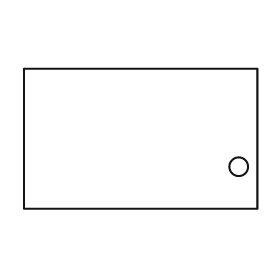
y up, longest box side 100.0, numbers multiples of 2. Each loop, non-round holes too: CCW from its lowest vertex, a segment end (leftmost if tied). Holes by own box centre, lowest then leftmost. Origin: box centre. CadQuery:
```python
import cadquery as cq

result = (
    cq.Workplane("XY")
    .moveTo(-50.0, -30.0)
    .lineTo(50.0, -30.0)
    .lineTo(50.0, 30.0)
    .lineTo(-50.0, 30.0)
    .close()
    .moveTo(42.0, -12.0)
    .circle(4.0)
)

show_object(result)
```